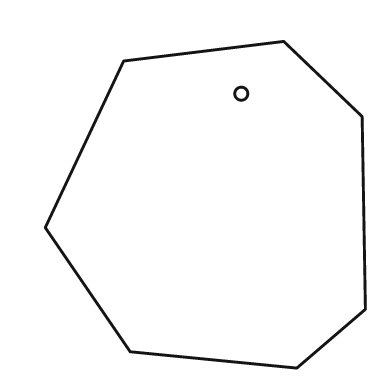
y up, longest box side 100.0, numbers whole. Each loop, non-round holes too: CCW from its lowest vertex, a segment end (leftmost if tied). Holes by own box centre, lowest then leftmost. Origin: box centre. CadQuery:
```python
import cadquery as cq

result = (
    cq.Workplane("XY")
    .moveTo(28.0, -50.0)
    .lineTo(49.0, -32.0)
    .lineTo(48.0, 27.0)
    .lineTo(24.0, 50.0)
    .lineTo(-25.0, 44.0)
    .lineTo(-49.0, -7.0)
    .lineTo(-23.0, -45.0)
    .close()
    .moveTo(11.0, 34.0)
    .circle(2.0)
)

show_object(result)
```